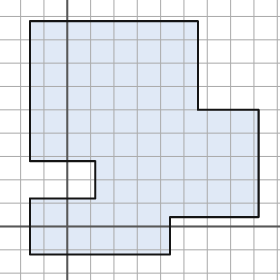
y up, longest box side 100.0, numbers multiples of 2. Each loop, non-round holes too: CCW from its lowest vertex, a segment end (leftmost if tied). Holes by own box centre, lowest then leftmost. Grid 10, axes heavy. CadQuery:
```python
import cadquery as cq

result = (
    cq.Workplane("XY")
    .moveTo(-16.0, -12.0)
    .lineTo(44.0, -12.0)
    .lineTo(44.0, 4.0)
    .lineTo(82.0, 4.0)
    .lineTo(82.0, 50.0)
    .lineTo(56.0, 50.0)
    .lineTo(56.0, 88.0)
    .lineTo(-16.0, 88.0)
    .lineTo(-16.0, 28.0)
    .lineTo(12.0, 28.0)
    .lineTo(12.0, 12.0)
    .lineTo(-16.0, 12.0)
    .close()
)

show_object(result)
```